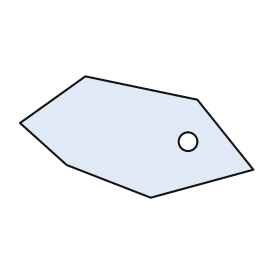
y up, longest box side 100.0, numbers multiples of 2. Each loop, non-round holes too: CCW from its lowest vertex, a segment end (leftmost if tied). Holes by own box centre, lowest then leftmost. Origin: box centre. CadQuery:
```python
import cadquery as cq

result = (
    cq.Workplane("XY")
    .moveTo(6.0, -26.0)
    .lineTo(50.0, -14.0)
    .lineTo(26.0, 16.0)
    .lineTo(-22.0, 26.0)
    .lineTo(-50.0, 6.0)
    .lineTo(-30.0, -12.0)
    .close()
    .moveTo(22.0, -2.0)
    .circle(4.0)
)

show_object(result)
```